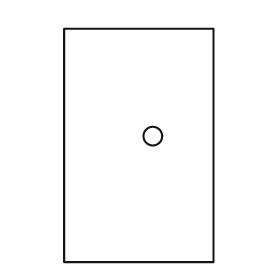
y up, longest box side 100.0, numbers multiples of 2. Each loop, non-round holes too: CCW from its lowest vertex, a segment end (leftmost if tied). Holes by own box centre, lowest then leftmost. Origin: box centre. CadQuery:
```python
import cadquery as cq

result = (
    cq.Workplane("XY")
    .moveTo(-32.0, -50.0)
    .lineTo(32.0, -50.0)
    .lineTo(32.0, 50.0)
    .lineTo(-32.0, 50.0)
    .close()
    .moveTo(6.0, 4.0)
    .circle(4.0)
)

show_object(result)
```